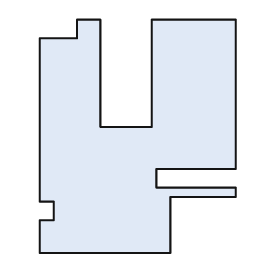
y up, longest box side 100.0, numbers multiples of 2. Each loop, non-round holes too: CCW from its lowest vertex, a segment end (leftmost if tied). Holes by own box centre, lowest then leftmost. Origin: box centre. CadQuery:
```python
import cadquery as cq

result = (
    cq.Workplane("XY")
    .moveTo(-42.0, -50.0)
    .lineTo(14.0, -50.0)
    .lineTo(14.0, -26.0)
    .lineTo(42.0, -26.0)
    .lineTo(42.0, -22.0)
    .lineTo(8.0, -22.0)
    .lineTo(8.0, -14.0)
    .lineTo(42.0, -14.0)
    .lineTo(42.0, 50.0)
    .lineTo(6.0, 50.0)
    .lineTo(6.0, 4.0)
    .lineTo(-16.0, 4.0)
    .lineTo(-16.0, 50.0)
    .lineTo(-26.0, 50.0)
    .lineTo(-26.0, 42.0)
    .lineTo(-42.0, 42.0)
    .lineTo(-42.0, -28.0)
    .lineTo(-36.0, -28.0)
    .lineTo(-36.0, -36.0)
    .lineTo(-42.0, -36.0)
    .close()
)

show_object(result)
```